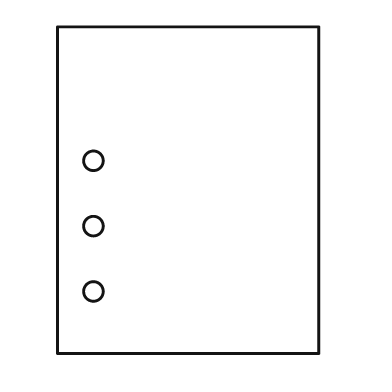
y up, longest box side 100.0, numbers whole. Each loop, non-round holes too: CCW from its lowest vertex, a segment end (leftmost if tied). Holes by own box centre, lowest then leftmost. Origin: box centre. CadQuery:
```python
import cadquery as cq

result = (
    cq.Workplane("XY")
    .moveTo(-40.0, -50.0)
    .lineTo(40.0, -50.0)
    .lineTo(40.0, 50.0)
    .lineTo(-40.0, 50.0)
    .close()
    .moveTo(-29.0, -31.0)
    .circle(3.0)
    .moveTo(-29.0, -11.0)
    .circle(3.0)
    .moveTo(-29.0, 9.0)
    .circle(3.0)
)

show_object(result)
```